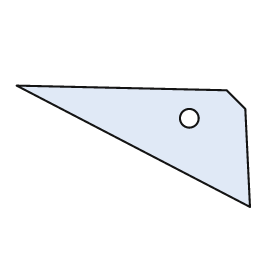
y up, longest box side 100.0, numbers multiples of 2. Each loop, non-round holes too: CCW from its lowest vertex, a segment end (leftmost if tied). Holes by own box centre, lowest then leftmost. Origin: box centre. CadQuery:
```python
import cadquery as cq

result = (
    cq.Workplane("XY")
    .moveTo(50.0, -26.0)
    .lineTo(48.0, 16.0)
    .lineTo(40.0, 24.0)
    .lineTo(-50.0, 26.0)
    .close()
    .moveTo(24.0, 12.0)
    .circle(4.0)
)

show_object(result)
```